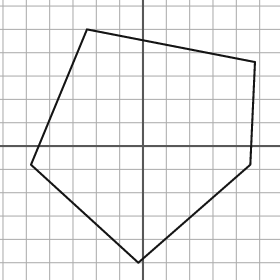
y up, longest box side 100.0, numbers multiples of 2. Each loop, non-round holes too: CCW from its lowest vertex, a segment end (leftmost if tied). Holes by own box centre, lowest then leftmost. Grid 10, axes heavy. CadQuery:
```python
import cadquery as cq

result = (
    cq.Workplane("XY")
    .moveTo(-2.0, -50.0)
    .lineTo(46.0, -8.0)
    .lineTo(48.0, 36.0)
    .lineTo(-24.0, 50.0)
    .lineTo(-48.0, -8.0)
    .close()
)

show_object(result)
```